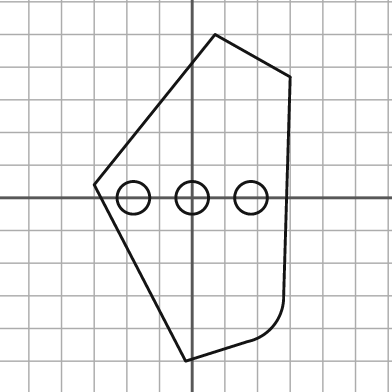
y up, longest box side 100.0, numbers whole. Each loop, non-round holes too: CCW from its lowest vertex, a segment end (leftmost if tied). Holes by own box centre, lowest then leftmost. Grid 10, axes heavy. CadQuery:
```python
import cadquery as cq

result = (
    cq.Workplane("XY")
    .moveTo(-2.0, -50.0)
    .lineTo(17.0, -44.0)
    .threePointArc((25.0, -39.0), (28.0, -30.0))
    .lineTo(30.0, 37.0)
    .lineTo(7.0, 50.0)
    .lineTo(-30.0, 4.0)
    .close()
    .moveTo(-18.0, 0.0)
    .circle(5.0)
    .moveTo(0.0, 0.0)
    .circle(5.0)
    .moveTo(18.0, 0.0)
    .circle(5.0)
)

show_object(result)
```